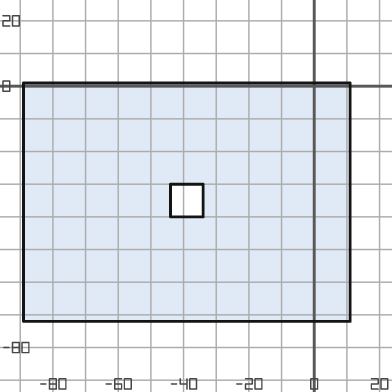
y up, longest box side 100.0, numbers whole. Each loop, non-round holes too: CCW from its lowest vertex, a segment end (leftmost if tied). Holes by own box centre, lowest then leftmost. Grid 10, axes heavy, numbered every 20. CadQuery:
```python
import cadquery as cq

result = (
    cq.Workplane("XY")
    .moveTo(-89.0, -72.0)
    .lineTo(11.0, -72.0)
    .lineTo(11.0, 1.0)
    .lineTo(-89.0, 1.0)
    .close()
    .moveTo(-44.0, -40.0)
    .lineTo(-34.0, -40.0)
    .lineTo(-34.0, -30.0)
    .lineTo(-44.0, -30.0)
    .close()
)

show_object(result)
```